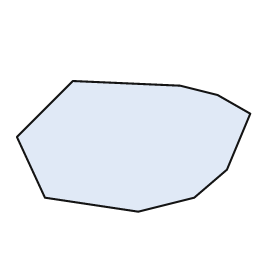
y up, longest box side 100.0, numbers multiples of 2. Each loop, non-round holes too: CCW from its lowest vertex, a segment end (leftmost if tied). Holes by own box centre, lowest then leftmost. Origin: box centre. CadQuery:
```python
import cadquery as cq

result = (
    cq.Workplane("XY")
    .moveTo(2.0, -28.0)
    .lineTo(26.0, -22.0)
    .lineTo(40.0, -10.0)
    .lineTo(50.0, 14.0)
    .lineTo(36.0, 22.0)
    .lineTo(20.0, 26.0)
    .lineTo(-26.0, 28.0)
    .lineTo(-50.0, 4.0)
    .lineTo(-38.0, -22.0)
    .close()
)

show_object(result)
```